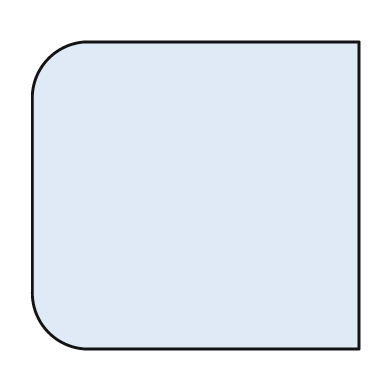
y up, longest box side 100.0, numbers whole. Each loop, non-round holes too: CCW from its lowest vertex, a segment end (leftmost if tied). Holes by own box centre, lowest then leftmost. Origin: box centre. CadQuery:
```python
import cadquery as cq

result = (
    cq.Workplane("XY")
    .moveTo(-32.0, -47.0)
    .lineTo(50.0, -47.0)
    .lineTo(50.0, 47.0)
    .lineTo(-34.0, 47.0)
    .threePointArc((-45.0, 42.0), (-50.0, 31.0))
    .lineTo(-50.0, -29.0)
    .threePointArc((-45.0, -42.0), (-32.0, -47.0))
    .close()
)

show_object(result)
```